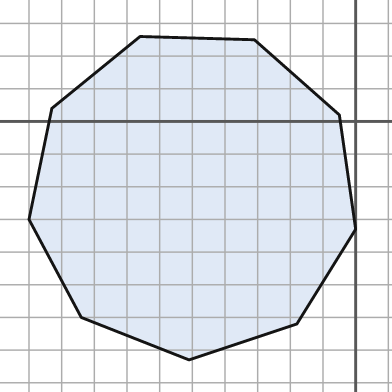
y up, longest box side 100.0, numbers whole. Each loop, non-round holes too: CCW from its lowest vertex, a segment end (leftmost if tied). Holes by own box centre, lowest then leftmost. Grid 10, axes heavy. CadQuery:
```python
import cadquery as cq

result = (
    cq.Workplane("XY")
    .moveTo(-51.0, -73.0)
    .lineTo(-18.0, -62.0)
    .lineTo(0.0, -33.0)
    .lineTo(-5.0, 2.0)
    .lineTo(-31.0, 25.0)
    .lineTo(-66.0, 26.0)
    .lineTo(-93.0, 4.0)
    .lineTo(-100.0, -30.0)
    .lineTo(-84.0, -60.0)
    .close()
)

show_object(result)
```